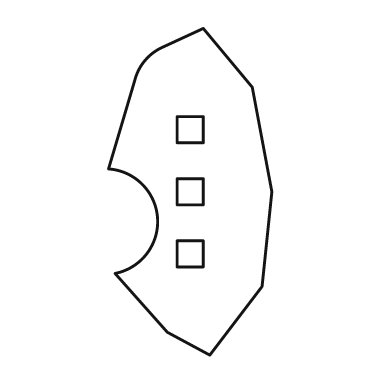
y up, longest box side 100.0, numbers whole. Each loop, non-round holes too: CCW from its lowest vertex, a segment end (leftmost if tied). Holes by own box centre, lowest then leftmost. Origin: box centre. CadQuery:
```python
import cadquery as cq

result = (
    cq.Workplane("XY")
    .moveTo(6.0, -50.0)
    .lineTo(22.0, -29.0)
    .lineTo(25.0, 0.0)
    .lineTo(19.0, 32.0)
    .lineTo(4.0, 50.0)
    .lineTo(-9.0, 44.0)
    .threePointArc((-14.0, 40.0), (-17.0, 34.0))
    .lineTo(-25.0, 7.0)
    .threePointArc((-10.0, -8.0), (-23.0, -25.0))
    .lineTo(-7.0, -43.0)
    .close()
    .moveTo(-4.0, -23.0)
    .lineTo(4.0, -23.0)
    .lineTo(4.0, -15.0)
    .lineTo(-4.0, -15.0)
    .close()
    .moveTo(-4.0, -4.0)
    .lineTo(4.0, -4.0)
    .lineTo(4.0, 4.0)
    .lineTo(-4.0, 4.0)
    .close()
    .moveTo(-4.0, 15.0)
    .lineTo(4.0, 15.0)
    .lineTo(4.0, 23.0)
    .lineTo(-4.0, 23.0)
    .close()
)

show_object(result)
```